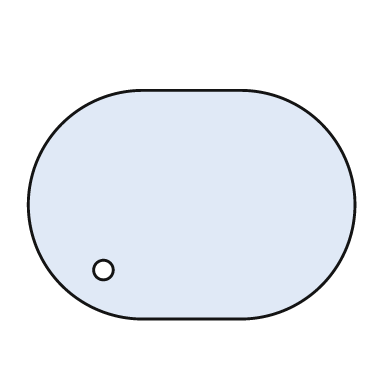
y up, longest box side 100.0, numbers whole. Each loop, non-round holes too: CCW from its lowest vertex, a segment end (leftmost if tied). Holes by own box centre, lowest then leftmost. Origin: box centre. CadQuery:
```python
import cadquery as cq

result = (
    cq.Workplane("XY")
    .moveTo(-15.0, -35.0)
    .lineTo(15.0, -35.0)
    .threePointArc((50.0, 0.0), (15.0, 35.0))
    .lineTo(-15.0, 35.0)
    .threePointArc((-50.0, 0.0), (-15.0, -35.0))
    .close()
    .moveTo(-27.0, -20.0)
    .circle(3.0)
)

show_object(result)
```